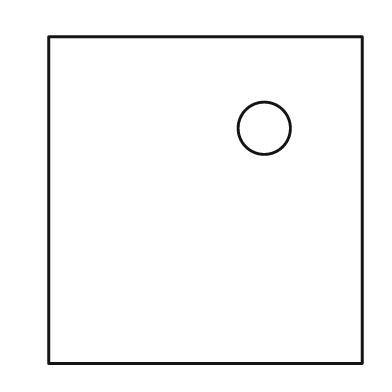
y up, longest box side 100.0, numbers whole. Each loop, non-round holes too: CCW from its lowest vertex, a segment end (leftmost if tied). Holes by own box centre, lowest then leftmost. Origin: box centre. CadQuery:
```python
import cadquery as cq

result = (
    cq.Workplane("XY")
    .moveTo(-48.0, -50.0)
    .lineTo(48.0, -50.0)
    .lineTo(48.0, 50.0)
    .lineTo(-48.0, 50.0)
    .close()
    .moveTo(18.0, 22.0)
    .circle(8.0)
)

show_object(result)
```